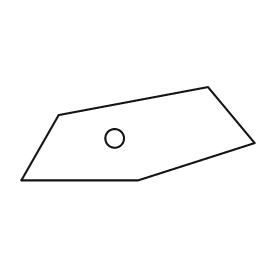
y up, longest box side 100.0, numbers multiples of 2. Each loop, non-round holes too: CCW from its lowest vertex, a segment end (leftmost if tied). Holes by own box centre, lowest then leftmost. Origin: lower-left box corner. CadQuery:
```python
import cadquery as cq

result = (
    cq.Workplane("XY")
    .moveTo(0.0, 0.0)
    .lineTo(50.0, 0.0)
    .lineTo(100.0, 16.0)
    .lineTo(80.0, 40.0)
    .lineTo(16.0, 28.0)
    .close()
    .moveTo(40.0, 18.0)
    .circle(4.0)
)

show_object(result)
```